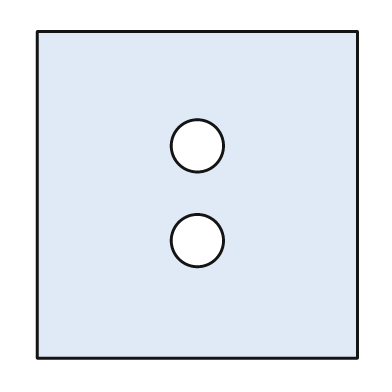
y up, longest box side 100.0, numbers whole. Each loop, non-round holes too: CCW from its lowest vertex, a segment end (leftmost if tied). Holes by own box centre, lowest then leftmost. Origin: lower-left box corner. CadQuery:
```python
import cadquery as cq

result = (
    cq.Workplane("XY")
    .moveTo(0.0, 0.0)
    .lineTo(98.0, 0.0)
    .lineTo(98.0, 100.0)
    .lineTo(0.0, 100.0)
    .close()
    .moveTo(49.0, 36.0)
    .circle(8.0)
    .moveTo(49.0, 65.0)
    .circle(8.0)
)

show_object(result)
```